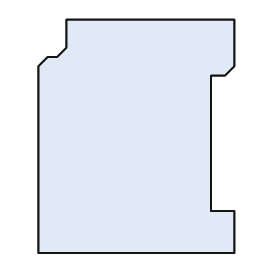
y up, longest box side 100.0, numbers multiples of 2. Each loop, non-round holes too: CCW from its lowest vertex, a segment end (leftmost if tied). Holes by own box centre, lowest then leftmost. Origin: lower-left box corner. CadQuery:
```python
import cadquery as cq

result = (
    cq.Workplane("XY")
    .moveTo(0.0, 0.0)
    .lineTo(84.0, 0.0)
    .lineTo(84.0, 18.0)
    .lineTo(74.0, 18.0)
    .lineTo(74.0, 76.0)
    .lineTo(80.0, 76.0)
    .lineTo(84.0, 80.0)
    .lineTo(84.0, 100.0)
    .lineTo(12.0, 100.0)
    .lineTo(12.0, 88.0)
    .lineTo(8.0, 84.0)
    .lineTo(4.0, 84.0)
    .lineTo(0.0, 80.0)
    .close()
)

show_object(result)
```